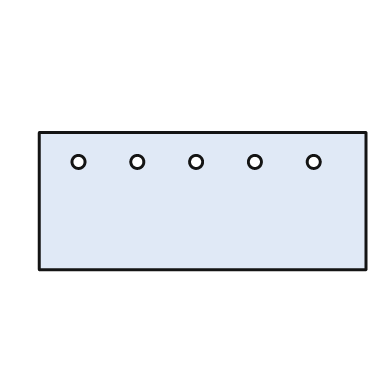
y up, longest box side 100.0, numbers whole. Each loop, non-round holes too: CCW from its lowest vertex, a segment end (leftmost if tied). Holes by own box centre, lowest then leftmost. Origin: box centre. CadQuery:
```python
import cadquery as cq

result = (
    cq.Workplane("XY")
    .moveTo(-50.0, -21.0)
    .lineTo(50.0, -21.0)
    .lineTo(50.0, 21.0)
    .lineTo(-50.0, 21.0)
    .close()
    .moveTo(-38.0, 12.0)
    .circle(2.0)
    .moveTo(-20.0, 12.0)
    .circle(2.0)
    .moveTo(-2.0, 12.0)
    .circle(2.0)
    .moveTo(16.0, 12.0)
    .circle(2.0)
    .moveTo(34.0, 12.0)
    .circle(2.0)
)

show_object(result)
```